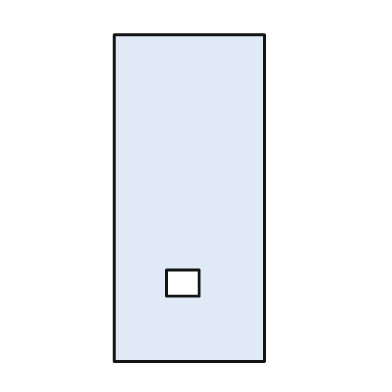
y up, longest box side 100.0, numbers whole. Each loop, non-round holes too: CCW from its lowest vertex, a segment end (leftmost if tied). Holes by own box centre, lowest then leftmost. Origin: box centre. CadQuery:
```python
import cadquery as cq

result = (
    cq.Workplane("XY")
    .moveTo(-23.0, -50.0)
    .lineTo(23.0, -50.0)
    .lineTo(23.0, 50.0)
    .lineTo(-23.0, 50.0)
    .close()
    .moveTo(-7.0, -30.0)
    .lineTo(3.0, -30.0)
    .lineTo(3.0, -22.0)
    .lineTo(-7.0, -22.0)
    .close()
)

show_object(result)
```